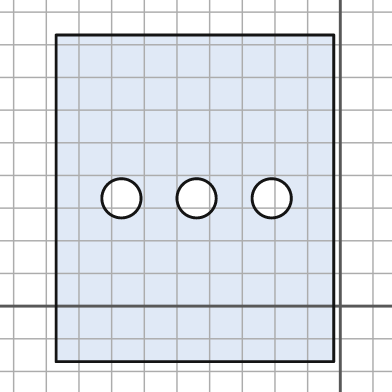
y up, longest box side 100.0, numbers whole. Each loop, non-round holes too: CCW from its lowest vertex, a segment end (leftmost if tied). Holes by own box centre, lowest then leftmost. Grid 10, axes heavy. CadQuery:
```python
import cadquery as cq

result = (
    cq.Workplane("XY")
    .moveTo(-87.0, -17.0)
    .lineTo(-2.0, -17.0)
    .lineTo(-2.0, 83.0)
    .lineTo(-87.0, 83.0)
    .close()
    .moveTo(-67.0, 33.0)
    .circle(6.0)
    .moveTo(-44.0, 33.0)
    .circle(6.0)
    .moveTo(-21.0, 33.0)
    .circle(6.0)
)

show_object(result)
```